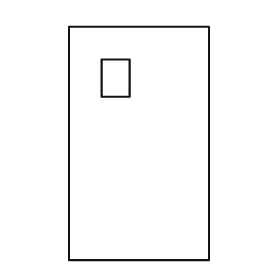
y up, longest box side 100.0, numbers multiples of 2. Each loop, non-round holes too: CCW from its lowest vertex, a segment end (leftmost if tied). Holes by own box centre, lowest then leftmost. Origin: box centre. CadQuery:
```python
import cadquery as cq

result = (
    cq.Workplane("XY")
    .moveTo(-30.0, -50.0)
    .lineTo(30.0, -50.0)
    .lineTo(30.0, 50.0)
    .lineTo(-30.0, 50.0)
    .close()
    .moveTo(-16.0, 20.0)
    .lineTo(-4.0, 20.0)
    .lineTo(-4.0, 36.0)
    .lineTo(-16.0, 36.0)
    .close()
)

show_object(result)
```